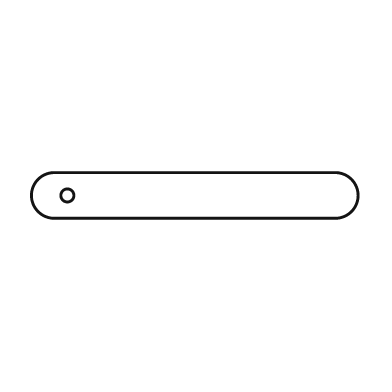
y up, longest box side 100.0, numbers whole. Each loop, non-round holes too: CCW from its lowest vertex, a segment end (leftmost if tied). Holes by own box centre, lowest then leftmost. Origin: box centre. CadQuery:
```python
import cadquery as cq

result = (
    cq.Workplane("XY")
    .moveTo(-43.0, -7.0)
    .lineTo(43.0, -7.0)
    .threePointArc((50.0, 0.0), (43.0, 7.0))
    .lineTo(-43.0, 7.0)
    .threePointArc((-50.0, 0.0), (-43.0, -7.0))
    .close()
    .moveTo(-39.0, 0.0)
    .circle(2.0)
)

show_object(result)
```